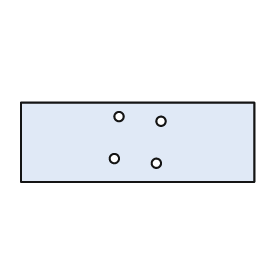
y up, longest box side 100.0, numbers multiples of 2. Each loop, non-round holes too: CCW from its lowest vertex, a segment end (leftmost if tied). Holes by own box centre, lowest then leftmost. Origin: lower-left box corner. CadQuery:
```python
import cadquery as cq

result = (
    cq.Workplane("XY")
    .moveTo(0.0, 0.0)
    .lineTo(100.0, 0.0)
    .lineTo(100.0, 34.0)
    .lineTo(0.0, 34.0)
    .close()
    .moveTo(58.0, 8.0)
    .circle(2.0)
    .moveTo(40.0, 10.0)
    .circle(2.0)
    .moveTo(60.0, 26.0)
    .circle(2.0)
    .moveTo(42.0, 28.0)
    .circle(2.0)
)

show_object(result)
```